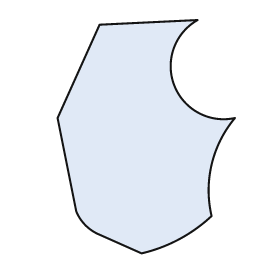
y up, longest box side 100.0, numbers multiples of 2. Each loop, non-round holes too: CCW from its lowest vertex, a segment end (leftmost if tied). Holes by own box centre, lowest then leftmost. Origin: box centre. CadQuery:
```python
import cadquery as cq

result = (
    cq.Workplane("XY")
    .moveTo(-2.0, -50.0)
    .threePointArc((14.0, -44.0), (28.0, -34.0))
    .threePointArc((28.0, -12.0), (38.0, 8.0))
    .threePointArc((12.0, 22.0), (22.0, 50.0))
    .lineTo(-20.0, 48.0)
    .lineTo(-38.0, 8.0)
    .lineTo(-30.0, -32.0)
    .threePointArc((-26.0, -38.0), (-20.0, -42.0))
    .close()
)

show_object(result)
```